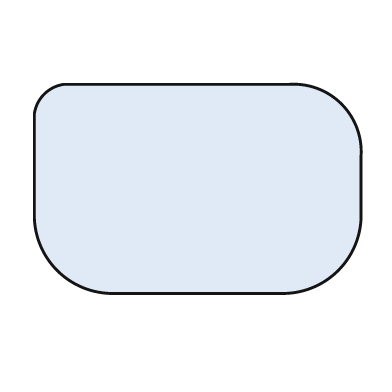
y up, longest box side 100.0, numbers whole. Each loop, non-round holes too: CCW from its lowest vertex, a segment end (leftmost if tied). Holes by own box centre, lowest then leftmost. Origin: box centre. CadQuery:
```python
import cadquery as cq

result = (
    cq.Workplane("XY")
    .moveTo(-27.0, -32.0)
    .lineTo(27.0, -32.0)
    .threePointArc((43.0, -25.0), (50.0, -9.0))
    .lineTo(50.0, 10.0)
    .threePointArc((44.0, 26.0), (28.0, 32.0))
    .lineTo(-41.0, 32.0)
    .threePointArc((-47.0, 29.0), (-50.0, 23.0))
    .lineTo(-50.0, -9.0)
    .threePointArc((-43.0, -25.0), (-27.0, -32.0))
    .close()
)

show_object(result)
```